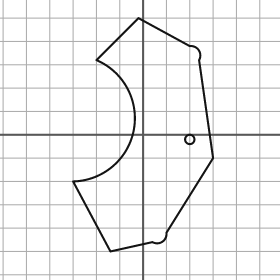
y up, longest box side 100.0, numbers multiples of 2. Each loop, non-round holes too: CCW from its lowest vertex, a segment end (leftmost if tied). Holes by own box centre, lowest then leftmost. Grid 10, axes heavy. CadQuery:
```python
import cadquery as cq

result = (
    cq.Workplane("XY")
    .moveTo(-14.0, -50.0)
    .lineTo(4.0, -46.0)
    .threePointArc((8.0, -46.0), (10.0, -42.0))
    .lineTo(30.0, -10.0)
    .lineTo(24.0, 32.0)
    .threePointArc((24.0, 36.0), (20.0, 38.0))
    .lineTo(-2.0, 50.0)
    .lineTo(-20.0, 32.0)
    .threePointArc((-4.0, 2.0), (-30.0, -20.0))
    .close()
    .moveTo(20.0, -2.0)
    .circle(2.0)
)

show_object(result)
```